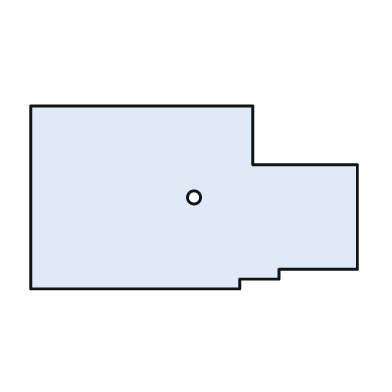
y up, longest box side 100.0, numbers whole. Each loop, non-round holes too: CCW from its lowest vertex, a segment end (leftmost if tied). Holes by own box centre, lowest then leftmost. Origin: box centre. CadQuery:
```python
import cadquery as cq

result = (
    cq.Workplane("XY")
    .moveTo(-50.0, -28.0)
    .lineTo(14.0, -28.0)
    .lineTo(14.0, -25.0)
    .lineTo(26.0, -25.0)
    .lineTo(26.0, -22.0)
    .lineTo(50.0, -22.0)
    .lineTo(50.0, 10.0)
    .lineTo(18.0, 10.0)
    .lineTo(18.0, 28.0)
    .lineTo(-50.0, 28.0)
    .close()
    .moveTo(0.0, 0.0)
    .circle(2.0)
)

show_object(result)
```